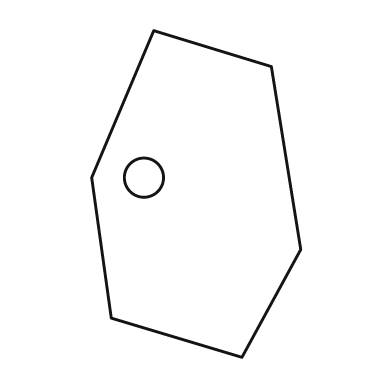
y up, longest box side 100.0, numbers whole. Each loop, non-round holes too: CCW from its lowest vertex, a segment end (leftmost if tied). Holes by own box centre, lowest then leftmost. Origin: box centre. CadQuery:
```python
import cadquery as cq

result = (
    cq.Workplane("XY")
    .moveTo(14.0, -50.0)
    .lineTo(32.0, -17.0)
    .lineTo(23.0, 39.0)
    .lineTo(-13.0, 50.0)
    .lineTo(-32.0, 5.0)
    .lineTo(-26.0, -38.0)
    .close()
    .moveTo(-16.0, 5.0)
    .circle(6.0)
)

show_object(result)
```